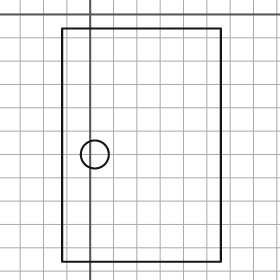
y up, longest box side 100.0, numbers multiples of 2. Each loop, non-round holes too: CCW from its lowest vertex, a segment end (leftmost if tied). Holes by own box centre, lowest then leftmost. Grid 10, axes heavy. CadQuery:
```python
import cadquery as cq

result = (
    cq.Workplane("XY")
    .moveTo(-12.0, -106.0)
    .lineTo(56.0, -106.0)
    .lineTo(56.0, -6.0)
    .lineTo(-12.0, -6.0)
    .close()
    .moveTo(2.0, -60.0)
    .circle(6.0)
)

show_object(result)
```